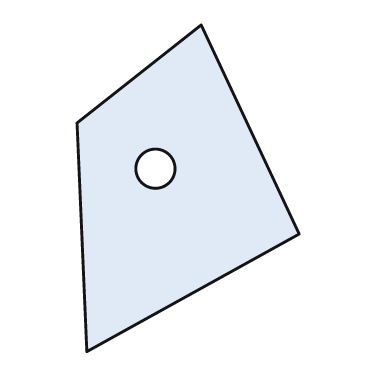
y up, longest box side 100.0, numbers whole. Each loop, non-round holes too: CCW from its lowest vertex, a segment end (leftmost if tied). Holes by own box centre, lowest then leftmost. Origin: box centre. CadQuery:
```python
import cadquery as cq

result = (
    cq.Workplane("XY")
    .moveTo(-31.0, -50.0)
    .lineTo(34.0, -14.0)
    .lineTo(4.0, 50.0)
    .lineTo(-34.0, 20.0)
    .close()
    .moveTo(-10.0, 6.0)
    .circle(6.0)
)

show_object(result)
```